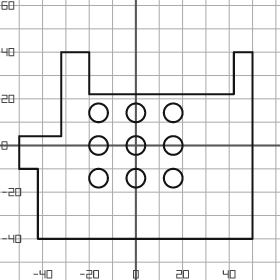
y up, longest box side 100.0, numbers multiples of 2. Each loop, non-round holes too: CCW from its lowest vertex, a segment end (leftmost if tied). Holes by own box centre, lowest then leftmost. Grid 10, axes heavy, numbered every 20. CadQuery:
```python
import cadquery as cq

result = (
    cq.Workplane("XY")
    .moveTo(-42.0, -40.0)
    .lineTo(50.0, -40.0)
    .lineTo(50.0, 40.0)
    .lineTo(42.0, 40.0)
    .lineTo(42.0, 22.0)
    .lineTo(-20.0, 22.0)
    .lineTo(-20.0, 40.0)
    .lineTo(-32.0, 40.0)
    .lineTo(-32.0, 4.0)
    .lineTo(-50.0, 4.0)
    .lineTo(-50.0, -10.0)
    .lineTo(-42.0, -10.0)
    .close()
    .moveTo(-16.0, -14.0)
    .circle(4.0)
    .moveTo(0.0, -14.0)
    .circle(4.0)
    .moveTo(16.0, -14.0)
    .circle(4.0)
    .moveTo(-16.0, 0.0)
    .circle(4.0)
    .moveTo(0.0, 0.0)
    .circle(4.0)
    .moveTo(16.0, 0.0)
    .circle(4.0)
    .moveTo(-16.0, 14.0)
    .circle(4.0)
    .moveTo(0.0, 14.0)
    .circle(4.0)
    .moveTo(16.0, 14.0)
    .circle(4.0)
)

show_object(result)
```